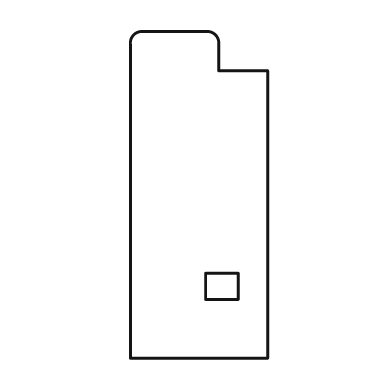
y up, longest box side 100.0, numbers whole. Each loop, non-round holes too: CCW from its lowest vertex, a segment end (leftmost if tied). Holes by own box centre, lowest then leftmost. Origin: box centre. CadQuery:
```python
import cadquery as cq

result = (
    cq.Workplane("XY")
    .moveTo(-21.0, -50.0)
    .lineTo(21.0, -50.0)
    .lineTo(21.0, 38.0)
    .lineTo(6.0, 38.0)
    .lineTo(6.0, 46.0)
    .threePointArc((5.0, 49.0), (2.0, 50.0))
    .lineTo(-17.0, 50.0)
    .threePointArc((-20.0, 49.0), (-21.0, 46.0))
    .close()
    .moveTo(2.0, -32.0)
    .lineTo(12.0, -32.0)
    .lineTo(12.0, -24.0)
    .lineTo(2.0, -24.0)
    .close()
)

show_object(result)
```